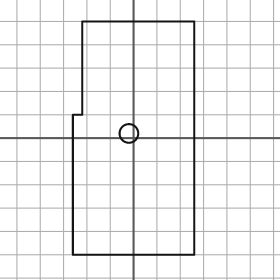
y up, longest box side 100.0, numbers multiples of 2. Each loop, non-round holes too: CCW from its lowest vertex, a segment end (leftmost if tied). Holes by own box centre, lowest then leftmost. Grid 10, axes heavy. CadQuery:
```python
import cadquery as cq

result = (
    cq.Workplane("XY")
    .moveTo(-26.0, -50.0)
    .lineTo(26.0, -50.0)
    .lineTo(26.0, 50.0)
    .lineTo(-22.0, 50.0)
    .lineTo(-22.0, 10.0)
    .lineTo(-26.0, 10.0)
    .close()
    .moveTo(-2.0, 2.0)
    .circle(4.0)
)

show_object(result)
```